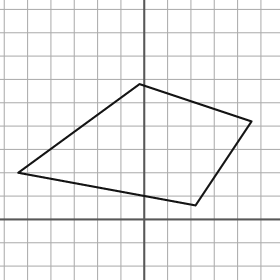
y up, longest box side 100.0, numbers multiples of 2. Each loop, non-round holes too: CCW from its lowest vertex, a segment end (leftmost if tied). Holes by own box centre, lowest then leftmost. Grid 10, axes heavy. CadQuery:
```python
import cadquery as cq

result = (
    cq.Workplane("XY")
    .moveTo(22.0, 6.0)
    .lineTo(46.0, 42.0)
    .lineTo(-2.0, 58.0)
    .lineTo(-54.0, 20.0)
    .close()
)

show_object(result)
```